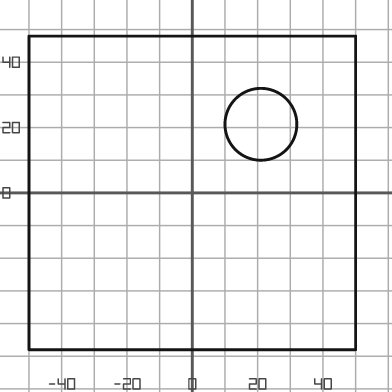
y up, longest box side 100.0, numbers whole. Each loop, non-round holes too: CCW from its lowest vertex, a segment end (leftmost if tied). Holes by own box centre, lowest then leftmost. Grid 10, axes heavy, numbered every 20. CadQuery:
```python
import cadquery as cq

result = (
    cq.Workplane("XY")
    .moveTo(-50.0, -48.0)
    .lineTo(50.0, -48.0)
    .lineTo(50.0, 48.0)
    .lineTo(-50.0, 48.0)
    .close()
    .moveTo(21.0, 21.0)
    .circle(11.0)
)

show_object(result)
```